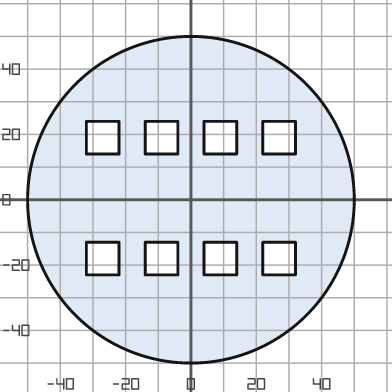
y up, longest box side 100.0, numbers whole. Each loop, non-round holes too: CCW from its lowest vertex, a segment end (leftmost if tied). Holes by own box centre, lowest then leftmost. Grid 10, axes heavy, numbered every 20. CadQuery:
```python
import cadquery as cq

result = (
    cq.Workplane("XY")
    .moveTo(0.0, 0.0)
    .circle(50.0)
    .moveTo(-32.0, -23.0)
    .lineTo(-22.0, -23.0)
    .lineTo(-22.0, -13.0)
    .lineTo(-32.0, -13.0)
    .close()
    .moveTo(-14.0, -23.0)
    .lineTo(-4.0, -23.0)
    .lineTo(-4.0, -13.0)
    .lineTo(-14.0, -13.0)
    .close()
    .moveTo(4.0, -23.0)
    .lineTo(14.0, -23.0)
    .lineTo(14.0, -13.0)
    .lineTo(4.0, -13.0)
    .close()
    .moveTo(22.0, -23.0)
    .lineTo(32.0, -23.0)
    .lineTo(32.0, -13.0)
    .lineTo(22.0, -13.0)
    .close()
    .moveTo(-32.0, 14.0)
    .lineTo(-22.0, 14.0)
    .lineTo(-22.0, 24.0)
    .lineTo(-32.0, 24.0)
    .close()
    .moveTo(-14.0, 14.0)
    .lineTo(-4.0, 14.0)
    .lineTo(-4.0, 24.0)
    .lineTo(-14.0, 24.0)
    .close()
    .moveTo(4.0, 14.0)
    .lineTo(14.0, 14.0)
    .lineTo(14.0, 24.0)
    .lineTo(4.0, 24.0)
    .close()
    .moveTo(22.0, 14.0)
    .lineTo(32.0, 14.0)
    .lineTo(32.0, 24.0)
    .lineTo(22.0, 24.0)
    .close()
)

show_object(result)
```